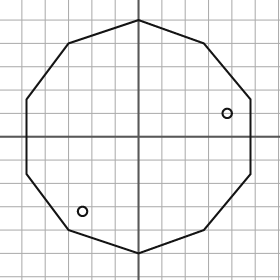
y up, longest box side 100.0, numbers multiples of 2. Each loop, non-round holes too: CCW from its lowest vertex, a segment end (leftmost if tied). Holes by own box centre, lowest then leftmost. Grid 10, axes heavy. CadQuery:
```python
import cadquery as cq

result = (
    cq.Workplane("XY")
    .moveTo(0.0, -50.0)
    .lineTo(28.0, -40.0)
    .lineTo(48.0, -16.0)
    .lineTo(48.0, 16.0)
    .lineTo(28.0, 40.0)
    .lineTo(0.0, 50.0)
    .lineTo(-30.0, 40.0)
    .lineTo(-48.0, 16.0)
    .lineTo(-48.0, -16.0)
    .lineTo(-30.0, -40.0)
    .close()
    .moveTo(-24.0, -32.0)
    .circle(2.0)
    .moveTo(38.0, 10.0)
    .circle(2.0)
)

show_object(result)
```